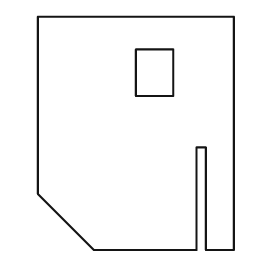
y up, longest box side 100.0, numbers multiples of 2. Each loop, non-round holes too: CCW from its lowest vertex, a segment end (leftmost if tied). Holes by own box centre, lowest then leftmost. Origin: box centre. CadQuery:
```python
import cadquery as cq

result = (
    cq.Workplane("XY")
    .moveTo(-18.0, -50.0)
    .lineTo(26.0, -50.0)
    .lineTo(26.0, -6.0)
    .lineTo(30.0, -6.0)
    .lineTo(30.0, -50.0)
    .lineTo(42.0, -50.0)
    .lineTo(42.0, 50.0)
    .lineTo(-42.0, 50.0)
    .lineTo(-42.0, -26.0)
    .close()
    .moveTo(0.0, 16.0)
    .lineTo(16.0, 16.0)
    .lineTo(16.0, 36.0)
    .lineTo(0.0, 36.0)
    .close()
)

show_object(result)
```